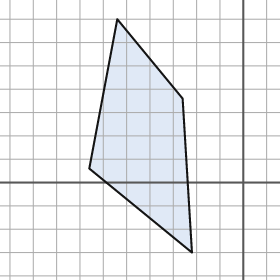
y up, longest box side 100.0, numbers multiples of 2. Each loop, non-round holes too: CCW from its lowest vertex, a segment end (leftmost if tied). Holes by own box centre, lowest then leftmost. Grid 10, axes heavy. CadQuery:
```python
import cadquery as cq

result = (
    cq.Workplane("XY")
    .moveTo(-22.0, -30.0)
    .lineTo(-26.0, 36.0)
    .lineTo(-54.0, 70.0)
    .lineTo(-66.0, 6.0)
    .close()
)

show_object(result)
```